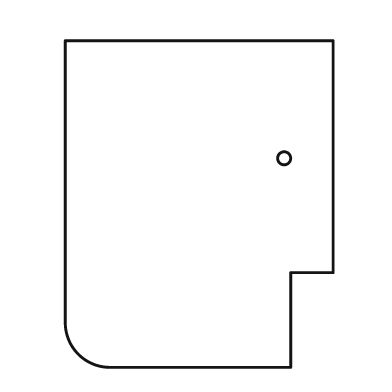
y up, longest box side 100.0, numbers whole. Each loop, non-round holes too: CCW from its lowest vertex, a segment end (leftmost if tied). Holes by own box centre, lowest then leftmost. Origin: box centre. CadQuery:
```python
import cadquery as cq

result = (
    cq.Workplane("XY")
    .moveTo(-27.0, -50.0)
    .lineTo(28.0, -50.0)
    .lineTo(28.0, -21.0)
    .lineTo(41.0, -21.0)
    .lineTo(41.0, 50.0)
    .lineTo(-41.0, 50.0)
    .lineTo(-41.0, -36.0)
    .threePointArc((-37.0, -46.0), (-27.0, -50.0))
    .close()
    .moveTo(26.0, 14.0)
    .circle(2.0)
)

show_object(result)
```